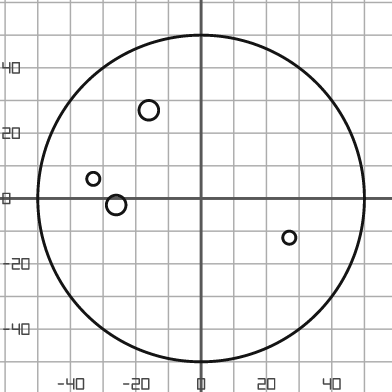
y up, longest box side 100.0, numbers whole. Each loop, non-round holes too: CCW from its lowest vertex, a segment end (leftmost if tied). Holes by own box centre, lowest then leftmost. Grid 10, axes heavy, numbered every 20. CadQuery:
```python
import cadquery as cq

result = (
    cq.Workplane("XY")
    .moveTo(0.0, 0.0)
    .circle(50.0)
    .moveTo(27.0, -12.0)
    .circle(2.0)
    .moveTo(-26.0, -2.0)
    .circle(3.0)
    .moveTo(-33.0, 6.0)
    .circle(2.0)
    .moveTo(-16.0, 27.0)
    .circle(3.0)
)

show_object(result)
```